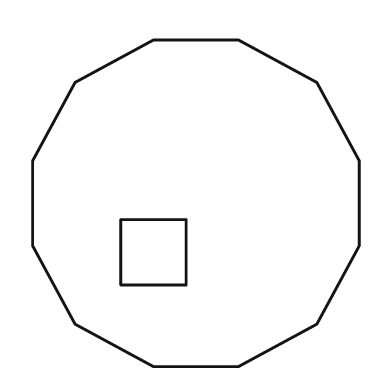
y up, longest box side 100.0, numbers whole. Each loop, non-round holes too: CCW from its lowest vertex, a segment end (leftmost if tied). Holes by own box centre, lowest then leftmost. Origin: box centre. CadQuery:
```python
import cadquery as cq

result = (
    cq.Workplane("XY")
    .moveTo(-13.0, -50.0)
    .lineTo(13.0, -50.0)
    .lineTo(37.0, -37.0)
    .lineTo(50.0, -13.0)
    .lineTo(50.0, 13.0)
    .lineTo(37.0, 37.0)
    .lineTo(13.0, 50.0)
    .lineTo(-13.0, 50.0)
    .lineTo(-37.0, 37.0)
    .lineTo(-50.0, 13.0)
    .lineTo(-50.0, -13.0)
    .lineTo(-37.0, -37.0)
    .close()
    .moveTo(-23.0, -25.0)
    .lineTo(-3.0, -25.0)
    .lineTo(-3.0, -5.0)
    .lineTo(-23.0, -5.0)
    .close()
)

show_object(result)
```